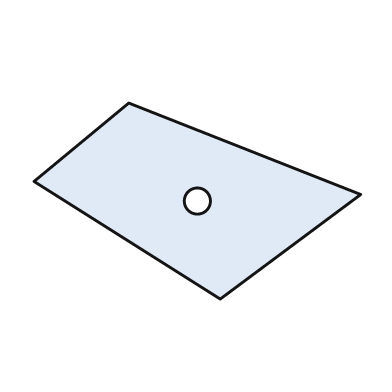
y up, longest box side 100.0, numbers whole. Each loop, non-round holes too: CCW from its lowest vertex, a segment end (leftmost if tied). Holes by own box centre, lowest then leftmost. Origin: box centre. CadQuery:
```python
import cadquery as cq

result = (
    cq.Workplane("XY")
    .moveTo(7.0, -30.0)
    .lineTo(50.0, 2.0)
    .lineTo(-21.0, 30.0)
    .lineTo(-50.0, 6.0)
    .close()
    .moveTo(0.0, 0.0)
    .circle(4.0)
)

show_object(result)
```